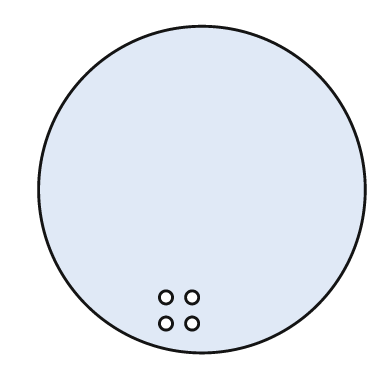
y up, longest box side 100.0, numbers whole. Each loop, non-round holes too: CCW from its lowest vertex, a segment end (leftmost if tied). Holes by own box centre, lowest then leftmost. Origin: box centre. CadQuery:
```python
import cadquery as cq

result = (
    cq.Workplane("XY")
    .moveTo(0.0, 0.0)
    .circle(50.0)
    .moveTo(-11.0, -41.0)
    .circle(2.0)
    .moveTo(-3.0, -41.0)
    .circle(2.0)
    .moveTo(-11.0, -33.0)
    .circle(2.0)
    .moveTo(-3.0, -33.0)
    .circle(2.0)
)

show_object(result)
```